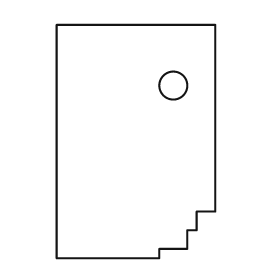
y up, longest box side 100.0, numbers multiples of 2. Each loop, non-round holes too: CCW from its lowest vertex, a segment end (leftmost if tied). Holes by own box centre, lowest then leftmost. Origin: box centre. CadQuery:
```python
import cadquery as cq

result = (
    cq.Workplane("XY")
    .moveTo(-34.0, -50.0)
    .lineTo(10.0, -50.0)
    .lineTo(10.0, -46.0)
    .lineTo(22.0, -46.0)
    .lineTo(22.0, -38.0)
    .lineTo(26.0, -38.0)
    .lineTo(26.0, -30.0)
    .lineTo(34.0, -30.0)
    .lineTo(34.0, 50.0)
    .lineTo(-34.0, 50.0)
    .close()
    .moveTo(16.0, 24.0)
    .circle(6.0)
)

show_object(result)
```